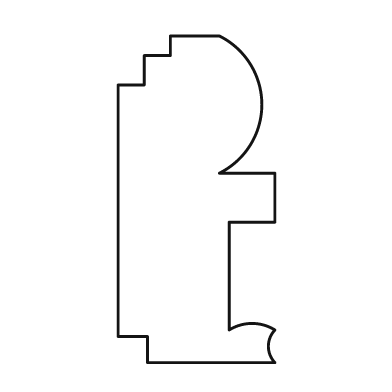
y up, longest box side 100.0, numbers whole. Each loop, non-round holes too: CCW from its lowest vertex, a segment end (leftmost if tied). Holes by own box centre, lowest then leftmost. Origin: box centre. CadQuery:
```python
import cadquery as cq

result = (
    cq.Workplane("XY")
    .moveTo(-15.0, -50.0)
    .lineTo(24.0, -50.0)
    .threePointArc((22.0, -45.0), (24.0, -40.0))
    .threePointArc((17.0, -38.0), (10.0, -40.0))
    .lineTo(10.0, -7.0)
    .lineTo(24.0, -7.0)
    .lineTo(24.0, 8.0)
    .lineTo(7.0, 8.0)
    .threePointArc((20.0, 29.0), (7.0, 50.0))
    .lineTo(-8.0, 50.0)
    .lineTo(-8.0, 44.0)
    .lineTo(-16.0, 44.0)
    .lineTo(-16.0, 35.0)
    .lineTo(-24.0, 35.0)
    .lineTo(-24.0, -42.0)
    .lineTo(-15.0, -42.0)
    .close()
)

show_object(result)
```